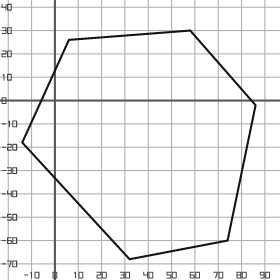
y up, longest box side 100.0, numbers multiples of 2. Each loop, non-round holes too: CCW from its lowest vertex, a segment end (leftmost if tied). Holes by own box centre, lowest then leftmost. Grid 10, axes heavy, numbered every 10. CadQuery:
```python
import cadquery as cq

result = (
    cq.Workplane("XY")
    .moveTo(32.0, -68.0)
    .lineTo(74.0, -60.0)
    .lineTo(86.0, -2.0)
    .lineTo(58.0, 30.0)
    .lineTo(6.0, 26.0)
    .lineTo(-14.0, -18.0)
    .close()
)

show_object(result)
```